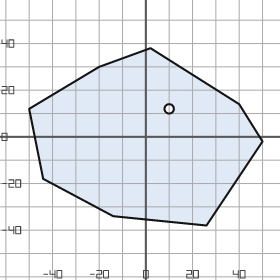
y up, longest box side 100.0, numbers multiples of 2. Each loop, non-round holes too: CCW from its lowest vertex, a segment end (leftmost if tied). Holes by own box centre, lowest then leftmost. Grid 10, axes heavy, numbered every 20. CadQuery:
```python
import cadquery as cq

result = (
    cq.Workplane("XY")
    .moveTo(26.0, -38.0)
    .lineTo(50.0, -2.0)
    .lineTo(40.0, 14.0)
    .lineTo(2.0, 38.0)
    .lineTo(-20.0, 30.0)
    .lineTo(-50.0, 12.0)
    .lineTo(-44.0, -18.0)
    .lineTo(-14.0, -34.0)
    .close()
    .moveTo(10.0, 12.0)
    .circle(2.0)
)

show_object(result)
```